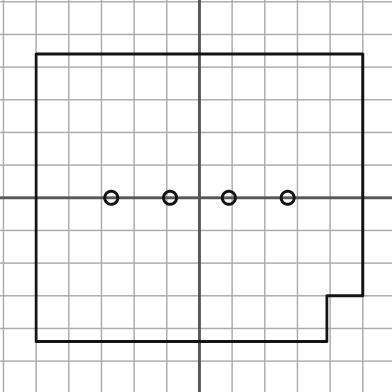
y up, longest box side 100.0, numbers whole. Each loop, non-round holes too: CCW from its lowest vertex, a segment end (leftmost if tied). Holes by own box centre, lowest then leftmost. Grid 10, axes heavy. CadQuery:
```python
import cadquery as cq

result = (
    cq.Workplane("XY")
    .moveTo(-50.0, -44.0)
    .lineTo(39.0, -44.0)
    .lineTo(39.0, -30.0)
    .lineTo(50.0, -30.0)
    .lineTo(50.0, 44.0)
    .lineTo(-50.0, 44.0)
    .close()
    .moveTo(-27.0, 0.0)
    .circle(2.0)
    .moveTo(-9.0, 0.0)
    .circle(2.0)
    .moveTo(9.0, 0.0)
    .circle(2.0)
    .moveTo(27.0, 0.0)
    .circle(2.0)
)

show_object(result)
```